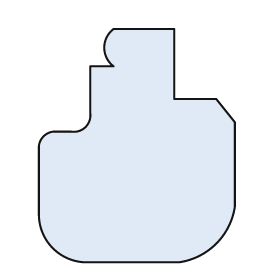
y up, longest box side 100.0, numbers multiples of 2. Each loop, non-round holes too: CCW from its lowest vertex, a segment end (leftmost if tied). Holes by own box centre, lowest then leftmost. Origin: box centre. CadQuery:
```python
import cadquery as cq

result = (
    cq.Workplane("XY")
    .moveTo(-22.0, -50.0)
    .lineTo(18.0, -50.0)
    .threePointArc((34.0, -42.0), (42.0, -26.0))
    .lineTo(42.0, 10.0)
    .lineTo(34.0, 20.0)
    .lineTo(16.0, 20.0)
    .lineTo(16.0, 50.0)
    .lineTo(-10.0, 50.0)
    .threePointArc((-14.0, 42.0), (-10.0, 34.0))
    .lineTo(-20.0, 34.0)
    .lineTo(-20.0, 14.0)
    .threePointArc((-22.0, 8.0), (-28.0, 6.0))
    .lineTo(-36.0, 6.0)
    .threePointArc((-40.0, 4.0), (-42.0, 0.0))
    .lineTo(-42.0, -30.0)
    .threePointArc((-36.0, -44.0), (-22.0, -50.0))
    .close()
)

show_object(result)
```